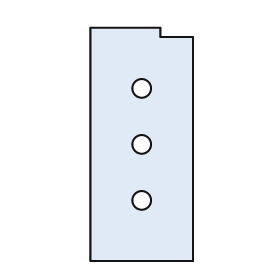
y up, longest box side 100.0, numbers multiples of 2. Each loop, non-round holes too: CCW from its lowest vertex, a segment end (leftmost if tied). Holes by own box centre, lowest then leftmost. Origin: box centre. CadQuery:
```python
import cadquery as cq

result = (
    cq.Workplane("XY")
    .moveTo(-22.0, -50.0)
    .lineTo(22.0, -50.0)
    .lineTo(22.0, 46.0)
    .lineTo(8.0, 46.0)
    .lineTo(8.0, 50.0)
    .lineTo(-22.0, 50.0)
    .close()
    .moveTo(0.0, -24.0)
    .circle(4.0)
    .moveTo(0.0, 0.0)
    .circle(4.0)
    .moveTo(0.0, 24.0)
    .circle(4.0)
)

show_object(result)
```